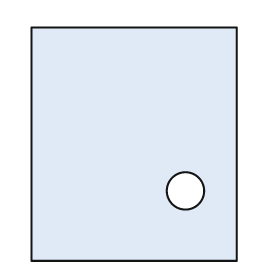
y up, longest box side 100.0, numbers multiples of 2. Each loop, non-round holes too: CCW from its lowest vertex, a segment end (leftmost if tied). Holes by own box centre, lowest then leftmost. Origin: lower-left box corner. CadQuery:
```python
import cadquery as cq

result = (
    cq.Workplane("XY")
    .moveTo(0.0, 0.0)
    .lineTo(88.0, 0.0)
    .lineTo(88.0, 100.0)
    .lineTo(0.0, 100.0)
    .close()
    .moveTo(66.0, 30.0)
    .circle(8.0)
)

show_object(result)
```